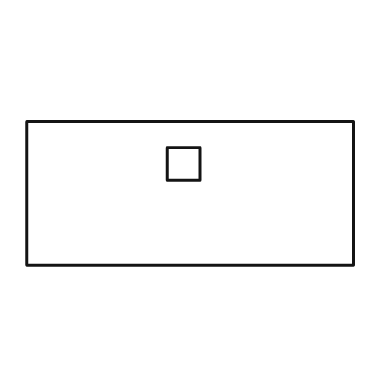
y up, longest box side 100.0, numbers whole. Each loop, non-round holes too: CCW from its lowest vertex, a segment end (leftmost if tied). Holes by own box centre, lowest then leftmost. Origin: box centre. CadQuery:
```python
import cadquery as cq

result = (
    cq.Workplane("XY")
    .moveTo(-50.0, -22.0)
    .lineTo(50.0, -22.0)
    .lineTo(50.0, 22.0)
    .lineTo(-50.0, 22.0)
    .close()
    .moveTo(-7.0, 4.0)
    .lineTo(3.0, 4.0)
    .lineTo(3.0, 14.0)
    .lineTo(-7.0, 14.0)
    .close()
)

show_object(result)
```